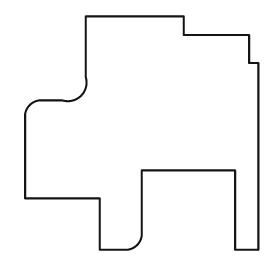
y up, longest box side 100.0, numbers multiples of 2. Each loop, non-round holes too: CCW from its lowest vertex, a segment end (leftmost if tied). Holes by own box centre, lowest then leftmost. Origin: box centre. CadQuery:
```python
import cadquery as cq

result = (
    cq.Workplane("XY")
    .moveTo(-18.0, -50.0)
    .lineTo(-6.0, -50.0)
    .threePointArc((-2.0, -48.0), (0.0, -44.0))
    .lineTo(0.0, -16.0)
    .lineTo(40.0, -16.0)
    .lineTo(40.0, -50.0)
    .lineTo(50.0, -50.0)
    .lineTo(50.0, 30.0)
    .lineTo(46.0, 30.0)
    .lineTo(46.0, 42.0)
    .lineTo(18.0, 42.0)
    .lineTo(18.0, 50.0)
    .lineTo(-24.0, 50.0)
    .lineTo(-24.0, 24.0)
    .threePointArc((-26.0, 16.0), (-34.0, 14.0))
    .lineTo(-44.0, 14.0)
    .threePointArc((-48.0, 12.0), (-50.0, 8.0))
    .lineTo(-50.0, -28.0)
    .lineTo(-18.0, -28.0)
    .close()
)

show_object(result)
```